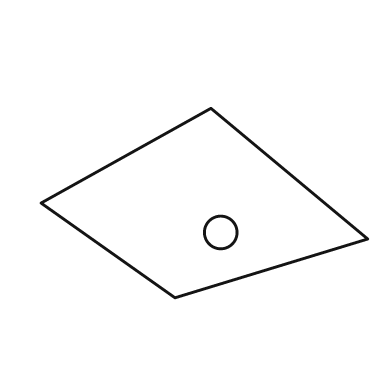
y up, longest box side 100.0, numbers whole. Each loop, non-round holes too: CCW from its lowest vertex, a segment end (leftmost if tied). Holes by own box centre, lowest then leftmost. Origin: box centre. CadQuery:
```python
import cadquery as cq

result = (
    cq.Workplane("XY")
    .moveTo(-9.0, -29.0)
    .lineTo(50.0, -11.0)
    .lineTo(2.0, 29.0)
    .lineTo(-50.0, 0.0)
    .close()
    .moveTo(5.0, -9.0)
    .circle(5.0)
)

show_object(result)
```